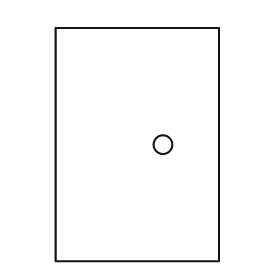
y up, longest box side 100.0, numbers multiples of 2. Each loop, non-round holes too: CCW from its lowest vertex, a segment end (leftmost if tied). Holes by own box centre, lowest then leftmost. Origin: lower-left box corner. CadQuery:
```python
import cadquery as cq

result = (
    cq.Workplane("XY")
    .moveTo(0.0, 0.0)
    .lineTo(70.0, 0.0)
    .lineTo(70.0, 100.0)
    .lineTo(0.0, 100.0)
    .close()
    .moveTo(46.0, 50.0)
    .circle(4.0)
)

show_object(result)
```